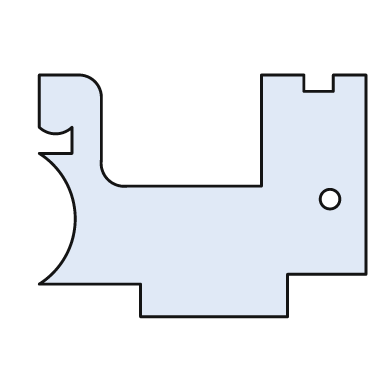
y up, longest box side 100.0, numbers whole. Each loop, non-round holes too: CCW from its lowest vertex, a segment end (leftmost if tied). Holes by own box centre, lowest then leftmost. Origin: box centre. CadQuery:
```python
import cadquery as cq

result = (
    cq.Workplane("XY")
    .moveTo(-19.0, -37.0)
    .lineTo(26.0, -37.0)
    .lineTo(26.0, -24.0)
    .lineTo(50.0, -24.0)
    .lineTo(50.0, 37.0)
    .lineTo(40.0, 37.0)
    .lineTo(40.0, 32.0)
    .lineTo(31.0, 32.0)
    .lineTo(31.0, 37.0)
    .lineTo(18.0, 37.0)
    .lineTo(18.0, 3.0)
    .lineTo(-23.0, 3.0)
    .threePointArc((-29.0, 5.0), (-31.0, 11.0))
    .lineTo(-31.0, 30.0)
    .threePointArc((-33.0, 35.0), (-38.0, 37.0))
    .lineTo(-50.0, 37.0)
    .lineTo(-50.0, 21.0)
    .threePointArc((-45.0, 19.0), (-40.0, 21.0))
    .lineTo(-40.0, 13.0)
    .lineTo(-50.0, 13.0)
    .threePointArc((-39.0, -7.0), (-50.0, -27.0))
    .lineTo(-19.0, -27.0)
    .close()
    .moveTo(39.0, -1.0)
    .circle(3.0)
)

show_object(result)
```